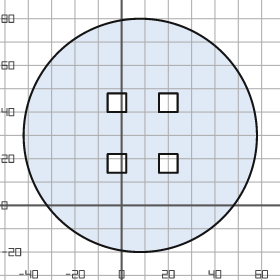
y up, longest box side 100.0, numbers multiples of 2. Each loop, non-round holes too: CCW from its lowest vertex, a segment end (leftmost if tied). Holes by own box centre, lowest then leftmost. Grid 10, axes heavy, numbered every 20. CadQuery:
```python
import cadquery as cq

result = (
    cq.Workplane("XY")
    .moveTo(8.0, 30.0)
    .circle(50.0)
    .moveTo(-6.0, 14.0)
    .lineTo(2.0, 14.0)
    .lineTo(2.0, 22.0)
    .lineTo(-6.0, 22.0)
    .close()
    .moveTo(16.0, 14.0)
    .lineTo(24.0, 14.0)
    .lineTo(24.0, 22.0)
    .lineTo(16.0, 22.0)
    .close()
    .moveTo(-6.0, 40.0)
    .lineTo(2.0, 40.0)
    .lineTo(2.0, 48.0)
    .lineTo(-6.0, 48.0)
    .close()
    .moveTo(16.0, 40.0)
    .lineTo(24.0, 40.0)
    .lineTo(24.0, 48.0)
    .lineTo(16.0, 48.0)
    .close()
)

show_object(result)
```